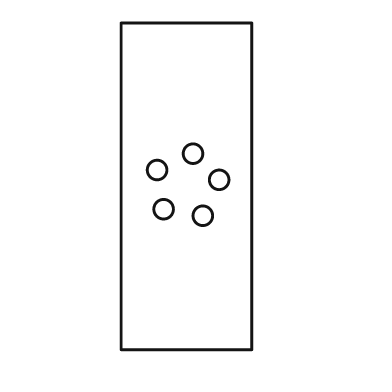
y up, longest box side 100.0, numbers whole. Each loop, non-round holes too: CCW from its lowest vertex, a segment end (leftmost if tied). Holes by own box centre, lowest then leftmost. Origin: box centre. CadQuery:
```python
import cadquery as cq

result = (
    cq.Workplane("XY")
    .moveTo(-20.0, -50.0)
    .lineTo(20.0, -50.0)
    .lineTo(20.0, 50.0)
    .lineTo(-20.0, 50.0)
    .close()
    .moveTo(5.0, -9.0)
    .circle(3.0)
    .moveTo(-7.0, -7.0)
    .circle(3.0)
    .moveTo(10.0, 2.0)
    .circle(3.0)
    .moveTo(-9.0, 5.0)
    .circle(3.0)
    .moveTo(2.0, 10.0)
    .circle(3.0)
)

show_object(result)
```